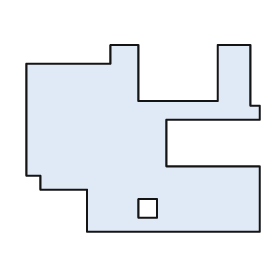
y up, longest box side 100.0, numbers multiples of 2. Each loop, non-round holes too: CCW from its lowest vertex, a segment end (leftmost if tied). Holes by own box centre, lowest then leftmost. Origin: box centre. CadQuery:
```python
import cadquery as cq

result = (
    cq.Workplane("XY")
    .moveTo(-24.0, -40.0)
    .lineTo(50.0, -40.0)
    .lineTo(50.0, -12.0)
    .lineTo(10.0, -12.0)
    .lineTo(10.0, 8.0)
    .lineTo(50.0, 8.0)
    .lineTo(50.0, 14.0)
    .lineTo(46.0, 14.0)
    .lineTo(46.0, 40.0)
    .lineTo(32.0, 40.0)
    .lineTo(32.0, 16.0)
    .lineTo(-2.0, 16.0)
    .lineTo(-2.0, 40.0)
    .lineTo(-14.0, 40.0)
    .lineTo(-14.0, 32.0)
    .lineTo(-50.0, 32.0)
    .lineTo(-50.0, -16.0)
    .lineTo(-44.0, -16.0)
    .lineTo(-44.0, -22.0)
    .lineTo(-24.0, -22.0)
    .close()
    .moveTo(-2.0, -34.0)
    .lineTo(6.0, -34.0)
    .lineTo(6.0, -26.0)
    .lineTo(-2.0, -26.0)
    .close()
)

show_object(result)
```